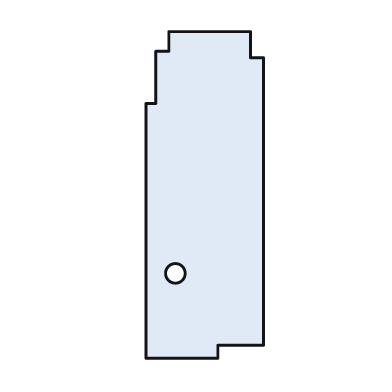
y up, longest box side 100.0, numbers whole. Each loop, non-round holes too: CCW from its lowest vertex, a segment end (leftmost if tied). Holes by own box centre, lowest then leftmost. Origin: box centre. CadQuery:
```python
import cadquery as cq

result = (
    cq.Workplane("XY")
    .moveTo(-18.0, -50.0)
    .lineTo(4.0, -50.0)
    .lineTo(4.0, -46.0)
    .lineTo(18.0, -46.0)
    .lineTo(18.0, 42.0)
    .lineTo(14.0, 42.0)
    .lineTo(14.0, 50.0)
    .lineTo(-11.0, 50.0)
    .lineTo(-11.0, 44.0)
    .lineTo(-15.0, 44.0)
    .lineTo(-15.0, 28.0)
    .lineTo(-18.0, 28.0)
    .close()
    .moveTo(-9.0, -24.0)
    .circle(3.0)
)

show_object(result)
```